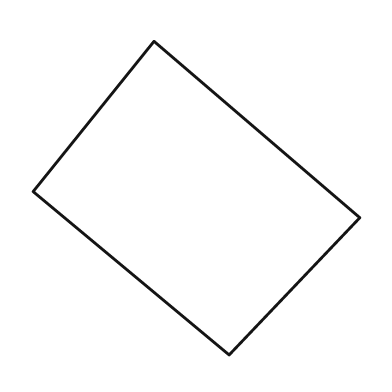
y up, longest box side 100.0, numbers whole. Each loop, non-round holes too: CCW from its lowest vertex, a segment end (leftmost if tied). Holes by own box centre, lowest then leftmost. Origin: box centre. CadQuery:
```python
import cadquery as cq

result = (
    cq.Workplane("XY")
    .moveTo(10.0, -48.0)
    .lineTo(50.0, -6.0)
    .lineTo(-13.0, 48.0)
    .lineTo(-50.0, 2.0)
    .close()
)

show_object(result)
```